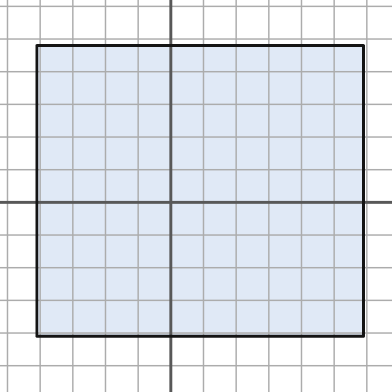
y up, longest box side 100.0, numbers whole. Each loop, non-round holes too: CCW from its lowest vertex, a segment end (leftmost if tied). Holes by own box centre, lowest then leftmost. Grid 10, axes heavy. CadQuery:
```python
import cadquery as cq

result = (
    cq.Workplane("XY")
    .moveTo(-41.0, -41.0)
    .lineTo(59.0, -41.0)
    .lineTo(59.0, 48.0)
    .lineTo(-41.0, 48.0)
    .close()
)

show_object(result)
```